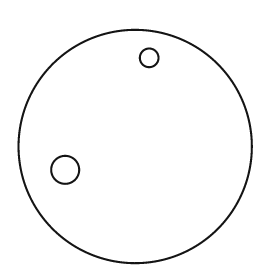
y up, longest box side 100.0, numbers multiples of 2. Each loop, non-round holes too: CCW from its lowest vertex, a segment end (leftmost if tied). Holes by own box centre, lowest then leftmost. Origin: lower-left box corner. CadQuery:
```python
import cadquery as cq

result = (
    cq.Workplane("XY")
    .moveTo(50.0, 50.0)
    .circle(50.0)
    .moveTo(20.0, 40.0)
    .circle(6.0)
    .moveTo(56.0, 88.0)
    .circle(4.0)
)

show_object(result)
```